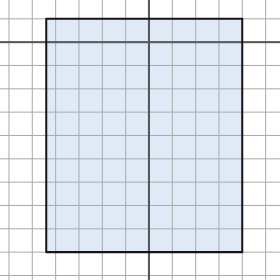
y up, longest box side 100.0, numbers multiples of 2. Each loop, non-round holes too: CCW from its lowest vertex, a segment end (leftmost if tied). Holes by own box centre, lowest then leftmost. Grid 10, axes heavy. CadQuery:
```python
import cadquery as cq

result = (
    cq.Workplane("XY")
    .moveTo(-44.0, -90.0)
    .lineTo(40.0, -90.0)
    .lineTo(40.0, 10.0)
    .lineTo(-44.0, 10.0)
    .close()
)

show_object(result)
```